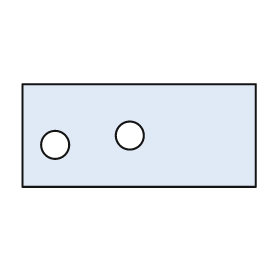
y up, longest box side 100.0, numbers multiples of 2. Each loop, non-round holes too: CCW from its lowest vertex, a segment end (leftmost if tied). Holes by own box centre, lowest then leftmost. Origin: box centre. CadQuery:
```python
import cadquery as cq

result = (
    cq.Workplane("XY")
    .moveTo(-50.0, -22.0)
    .lineTo(50.0, -22.0)
    .lineTo(50.0, 22.0)
    .lineTo(-50.0, 22.0)
    .close()
    .moveTo(-36.0, -4.0)
    .circle(6.0)
    .moveTo(-4.0, 0.0)
    .circle(6.0)
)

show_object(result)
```